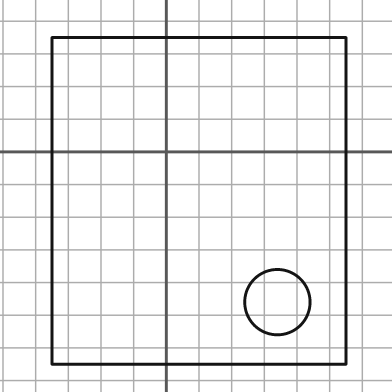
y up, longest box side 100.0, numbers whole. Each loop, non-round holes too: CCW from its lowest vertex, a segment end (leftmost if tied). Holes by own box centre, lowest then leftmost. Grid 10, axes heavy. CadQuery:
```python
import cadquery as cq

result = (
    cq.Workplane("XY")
    .moveTo(-35.0, -65.0)
    .lineTo(55.0, -65.0)
    .lineTo(55.0, 35.0)
    .lineTo(-35.0, 35.0)
    .close()
    .moveTo(34.0, -46.0)
    .circle(10.0)
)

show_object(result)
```